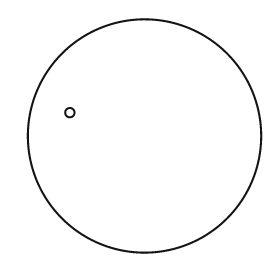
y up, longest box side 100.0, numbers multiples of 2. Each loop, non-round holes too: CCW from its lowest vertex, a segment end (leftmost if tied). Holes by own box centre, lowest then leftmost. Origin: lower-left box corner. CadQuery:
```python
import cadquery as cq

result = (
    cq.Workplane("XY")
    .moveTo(50.0, 50.0)
    .circle(50.0)
    .moveTo(18.0, 60.0)
    .circle(2.0)
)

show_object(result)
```